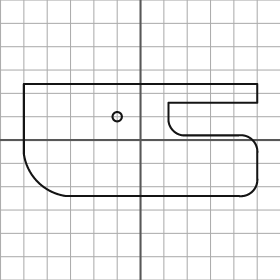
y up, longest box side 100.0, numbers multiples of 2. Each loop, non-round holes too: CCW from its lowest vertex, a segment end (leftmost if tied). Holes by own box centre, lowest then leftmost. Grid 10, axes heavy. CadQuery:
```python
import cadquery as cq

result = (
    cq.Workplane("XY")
    .moveTo(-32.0, -24.0)
    .lineTo(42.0, -24.0)
    .threePointArc((48.0, -22.0), (50.0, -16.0))
    .lineTo(50.0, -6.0)
    .threePointArc((48.0, 0.0), (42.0, 2.0))
    .lineTo(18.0, 2.0)
    .threePointArc((14.0, 4.0), (12.0, 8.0))
    .lineTo(12.0, 16.0)
    .lineTo(50.0, 16.0)
    .lineTo(50.0, 24.0)
    .lineTo(-50.0, 24.0)
    .lineTo(-50.0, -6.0)
    .threePointArc((-44.0, -18.0), (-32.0, -24.0))
    .close()
    .moveTo(-10.0, 10.0)
    .circle(2.0)
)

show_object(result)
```